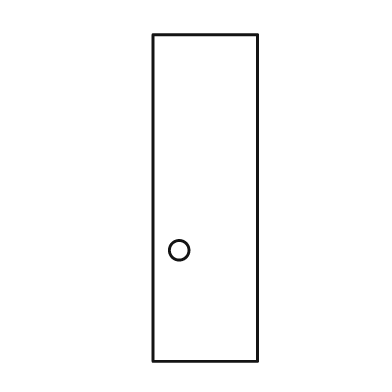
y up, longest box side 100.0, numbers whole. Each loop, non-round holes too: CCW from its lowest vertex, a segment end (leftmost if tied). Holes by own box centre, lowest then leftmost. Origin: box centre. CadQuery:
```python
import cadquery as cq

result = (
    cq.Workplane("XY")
    .moveTo(-16.0, -50.0)
    .lineTo(16.0, -50.0)
    .lineTo(16.0, 50.0)
    .lineTo(-16.0, 50.0)
    .close()
    .moveTo(-8.0, -16.0)
    .circle(3.0)
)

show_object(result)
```